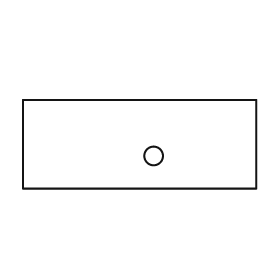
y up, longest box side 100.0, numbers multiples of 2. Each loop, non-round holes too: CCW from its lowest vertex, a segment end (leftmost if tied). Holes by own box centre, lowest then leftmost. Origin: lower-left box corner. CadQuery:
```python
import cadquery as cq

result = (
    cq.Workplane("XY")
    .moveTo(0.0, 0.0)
    .lineTo(100.0, 0.0)
    .lineTo(100.0, 38.0)
    .lineTo(0.0, 38.0)
    .close()
    .moveTo(56.0, 14.0)
    .circle(4.0)
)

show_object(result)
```